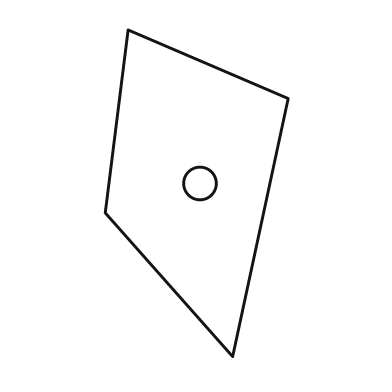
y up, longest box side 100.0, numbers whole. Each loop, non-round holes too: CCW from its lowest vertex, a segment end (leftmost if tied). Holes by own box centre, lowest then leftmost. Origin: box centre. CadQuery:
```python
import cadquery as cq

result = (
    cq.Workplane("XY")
    .moveTo(11.0, -50.0)
    .lineTo(28.0, 29.0)
    .lineTo(-21.0, 50.0)
    .lineTo(-28.0, -6.0)
    .close()
    .moveTo(1.0, 3.0)
    .circle(5.0)
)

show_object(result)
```